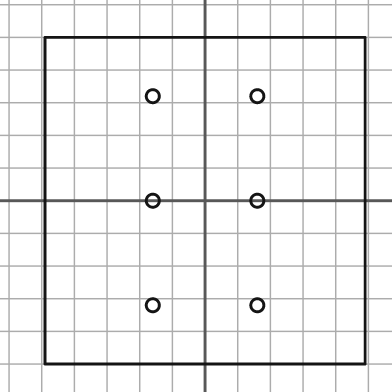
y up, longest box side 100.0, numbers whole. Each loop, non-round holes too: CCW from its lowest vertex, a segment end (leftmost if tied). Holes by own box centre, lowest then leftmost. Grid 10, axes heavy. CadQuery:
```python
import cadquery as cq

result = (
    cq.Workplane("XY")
    .moveTo(-49.0, -50.0)
    .lineTo(49.0, -50.0)
    .lineTo(49.0, 50.0)
    .lineTo(-49.0, 50.0)
    .close()
    .moveTo(-16.0, -32.0)
    .circle(2.0)
    .moveTo(16.0, -32.0)
    .circle(2.0)
    .moveTo(-16.0, 0.0)
    .circle(2.0)
    .moveTo(16.0, 0.0)
    .circle(2.0)
    .moveTo(-16.0, 32.0)
    .circle(2.0)
    .moveTo(16.0, 32.0)
    .circle(2.0)
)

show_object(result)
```